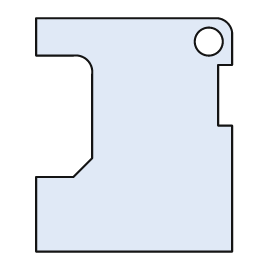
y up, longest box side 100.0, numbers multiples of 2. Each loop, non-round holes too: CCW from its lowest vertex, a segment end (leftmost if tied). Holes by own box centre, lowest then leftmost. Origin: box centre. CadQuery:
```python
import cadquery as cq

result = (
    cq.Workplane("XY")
    .moveTo(-42.0, -50.0)
    .lineTo(42.0, -50.0)
    .lineTo(42.0, 4.0)
    .lineTo(36.0, 4.0)
    .lineTo(36.0, 30.0)
    .lineTo(42.0, 30.0)
    .lineTo(42.0, 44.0)
    .threePointArc((40.0, 48.0), (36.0, 50.0))
    .lineTo(-42.0, 50.0)
    .lineTo(-42.0, 34.0)
    .lineTo(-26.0, 34.0)
    .threePointArc((-20.0, 32.0), (-18.0, 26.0))
    .lineTo(-18.0, -10.0)
    .lineTo(-26.0, -18.0)
    .lineTo(-42.0, -18.0)
    .close()
    .moveTo(32.0, 40.0)
    .circle(6.0)
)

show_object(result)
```